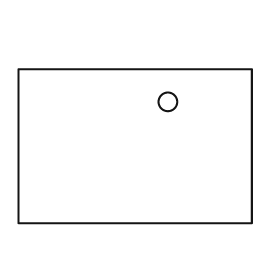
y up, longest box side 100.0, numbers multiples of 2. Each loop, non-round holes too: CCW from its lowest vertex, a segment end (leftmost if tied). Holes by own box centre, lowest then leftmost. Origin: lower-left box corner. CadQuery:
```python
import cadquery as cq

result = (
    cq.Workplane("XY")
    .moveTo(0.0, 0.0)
    .lineTo(100.0, 0.0)
    .lineTo(100.0, 66.0)
    .lineTo(0.0, 66.0)
    .close()
    .moveTo(64.0, 52.0)
    .circle(4.0)
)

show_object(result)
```